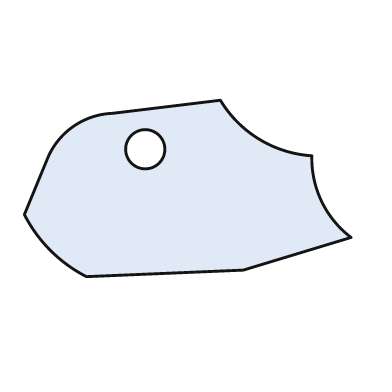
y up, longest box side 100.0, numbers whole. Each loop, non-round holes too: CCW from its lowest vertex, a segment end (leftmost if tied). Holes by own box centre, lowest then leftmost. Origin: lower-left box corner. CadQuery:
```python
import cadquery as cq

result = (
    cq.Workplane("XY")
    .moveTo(19.0, 0.0)
    .lineTo(67.0, 2.0)
    .lineTo(100.0, 12.0)
    .threePointArc((91.0, 23.0), (88.0, 37.0))
    .threePointArc((72.0, 42.0), (60.0, 54.0))
    .lineTo(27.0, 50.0)
    .threePointArc((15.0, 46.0), (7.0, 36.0))
    .lineTo(0.0, 19.0)
    .threePointArc((8.0, 8.0), (19.0, 0.0))
    .close()
    .moveTo(37.0, 39.0)
    .circle(6.0)
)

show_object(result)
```